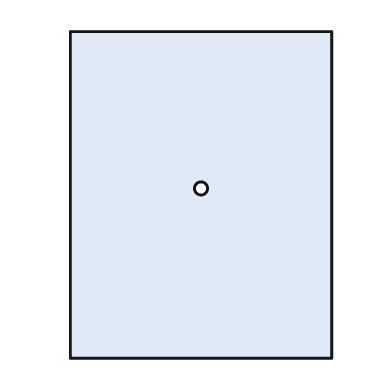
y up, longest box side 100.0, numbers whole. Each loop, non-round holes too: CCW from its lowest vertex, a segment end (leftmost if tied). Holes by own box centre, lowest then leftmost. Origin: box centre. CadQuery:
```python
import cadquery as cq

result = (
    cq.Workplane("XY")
    .moveTo(-40.0, -50.0)
    .lineTo(40.0, -50.0)
    .lineTo(40.0, 50.0)
    .lineTo(-40.0, 50.0)
    .close()
    .moveTo(0.0, 2.0)
    .circle(2.0)
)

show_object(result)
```